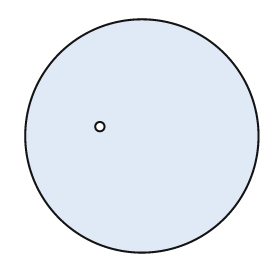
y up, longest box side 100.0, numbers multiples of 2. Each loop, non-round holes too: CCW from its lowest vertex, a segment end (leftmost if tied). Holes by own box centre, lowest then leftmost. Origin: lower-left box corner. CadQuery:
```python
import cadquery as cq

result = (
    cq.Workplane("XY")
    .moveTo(50.0, 50.0)
    .circle(50.0)
    .moveTo(32.0, 54.0)
    .circle(2.0)
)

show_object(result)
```